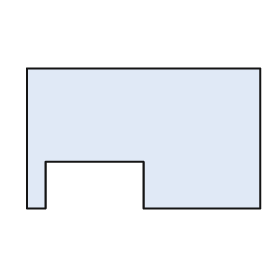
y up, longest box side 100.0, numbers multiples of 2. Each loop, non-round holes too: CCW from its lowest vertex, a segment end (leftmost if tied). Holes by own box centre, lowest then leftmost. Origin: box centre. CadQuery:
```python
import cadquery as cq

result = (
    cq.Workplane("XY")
    .moveTo(-50.0, -30.0)
    .lineTo(-42.0, -30.0)
    .lineTo(-42.0, -10.0)
    .lineTo(0.0, -10.0)
    .lineTo(0.0, -30.0)
    .lineTo(50.0, -30.0)
    .lineTo(50.0, 30.0)
    .lineTo(-50.0, 30.0)
    .close()
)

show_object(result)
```